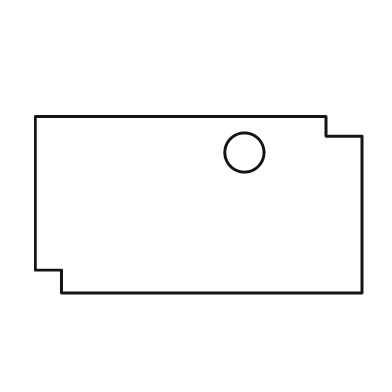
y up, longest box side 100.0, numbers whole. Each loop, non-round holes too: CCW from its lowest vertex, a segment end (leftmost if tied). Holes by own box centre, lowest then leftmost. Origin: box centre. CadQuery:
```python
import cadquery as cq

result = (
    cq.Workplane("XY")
    .moveTo(-42.0, -27.0)
    .lineTo(50.0, -27.0)
    .lineTo(50.0, 21.0)
    .lineTo(39.0, 21.0)
    .lineTo(39.0, 27.0)
    .lineTo(-50.0, 27.0)
    .lineTo(-50.0, -20.0)
    .lineTo(-42.0, -20.0)
    .close()
    .moveTo(14.0, 16.0)
    .circle(6.0)
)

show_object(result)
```